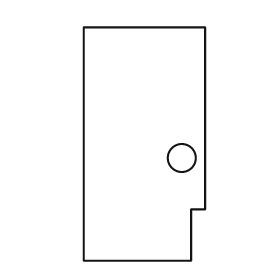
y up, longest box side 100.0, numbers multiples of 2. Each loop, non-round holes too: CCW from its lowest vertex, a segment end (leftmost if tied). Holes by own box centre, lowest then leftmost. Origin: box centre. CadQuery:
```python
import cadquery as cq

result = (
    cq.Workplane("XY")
    .moveTo(-26.0, -50.0)
    .lineTo(20.0, -50.0)
    .lineTo(20.0, -28.0)
    .lineTo(26.0, -28.0)
    .lineTo(26.0, 50.0)
    .lineTo(-26.0, 50.0)
    .close()
    .moveTo(16.0, -6.0)
    .circle(6.0)
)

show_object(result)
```